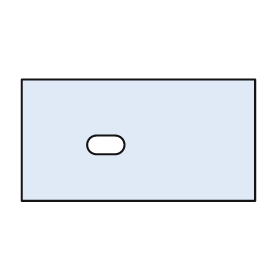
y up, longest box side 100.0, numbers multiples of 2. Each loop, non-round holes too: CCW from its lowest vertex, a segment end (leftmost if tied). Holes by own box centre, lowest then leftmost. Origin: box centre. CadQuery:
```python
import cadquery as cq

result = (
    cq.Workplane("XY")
    .moveTo(-50.0, -26.0)
    .lineTo(50.0, -26.0)
    .lineTo(50.0, 26.0)
    .lineTo(-50.0, 26.0)
    .close()
    .moveTo(-18.0, -6.0)
    .lineTo(-10.0, -6.0)
    .threePointArc((-6.0, -2.0), (-10.0, 2.0))
    .lineTo(-18.0, 2.0)
    .threePointArc((-22.0, -2.0), (-18.0, -6.0))
    .close()
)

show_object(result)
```